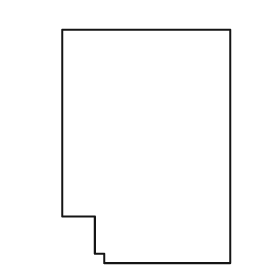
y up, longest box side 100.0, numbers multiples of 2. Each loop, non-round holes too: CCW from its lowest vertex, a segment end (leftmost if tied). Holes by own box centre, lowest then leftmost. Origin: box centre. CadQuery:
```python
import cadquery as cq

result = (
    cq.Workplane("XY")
    .moveTo(-18.0, -50.0)
    .lineTo(36.0, -50.0)
    .lineTo(36.0, 50.0)
    .lineTo(-36.0, 50.0)
    .lineTo(-36.0, -30.0)
    .lineTo(-22.0, -30.0)
    .lineTo(-22.0, -46.0)
    .lineTo(-18.0, -46.0)
    .close()
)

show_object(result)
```